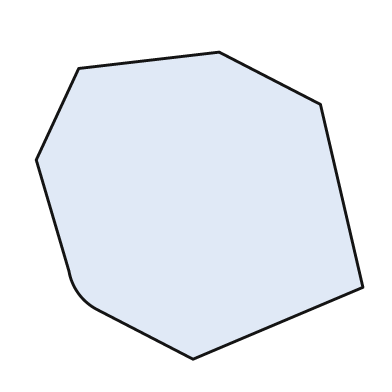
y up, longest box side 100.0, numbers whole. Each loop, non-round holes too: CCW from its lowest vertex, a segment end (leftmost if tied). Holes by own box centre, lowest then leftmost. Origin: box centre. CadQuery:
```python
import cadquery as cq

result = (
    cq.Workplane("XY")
    .moveTo(-2.0, -47.0)
    .lineTo(50.0, -25.0)
    .lineTo(37.0, 31.0)
    .lineTo(6.0, 47.0)
    .lineTo(-37.0, 42.0)
    .lineTo(-50.0, 14.0)
    .lineTo(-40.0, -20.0)
    .threePointArc((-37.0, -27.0), (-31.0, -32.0))
    .close()
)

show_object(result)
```